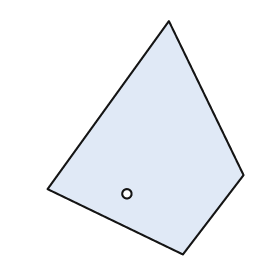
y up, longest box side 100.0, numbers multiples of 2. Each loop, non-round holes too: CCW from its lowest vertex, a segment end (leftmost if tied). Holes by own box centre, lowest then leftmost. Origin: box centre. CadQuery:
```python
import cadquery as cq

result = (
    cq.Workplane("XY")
    .moveTo(16.0, -50.0)
    .lineTo(42.0, -16.0)
    .lineTo(10.0, 50.0)
    .lineTo(-42.0, -22.0)
    .close()
    .moveTo(-8.0, -24.0)
    .circle(2.0)
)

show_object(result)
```